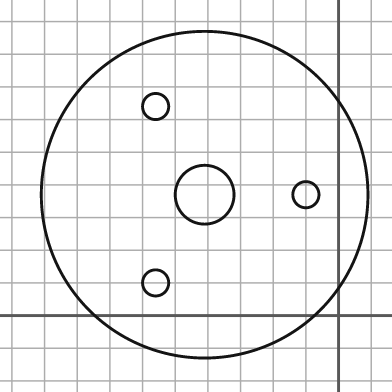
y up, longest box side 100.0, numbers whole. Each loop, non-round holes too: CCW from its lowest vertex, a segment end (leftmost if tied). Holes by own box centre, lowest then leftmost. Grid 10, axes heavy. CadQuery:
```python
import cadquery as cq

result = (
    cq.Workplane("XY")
    .moveTo(-41.0, 37.0)
    .circle(50.0)
    .moveTo(-56.0, 10.0)
    .circle(4.0)
    .moveTo(-41.0, 37.0)
    .circle(9.0)
    .moveTo(-10.0, 37.0)
    .circle(4.0)
    .moveTo(-56.0, 64.0)
    .circle(4.0)
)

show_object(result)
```